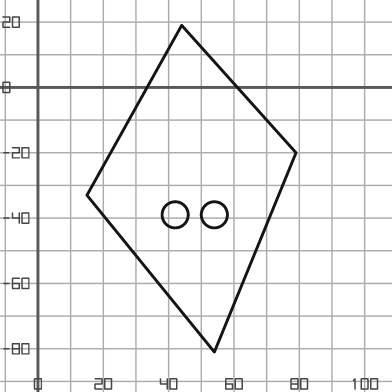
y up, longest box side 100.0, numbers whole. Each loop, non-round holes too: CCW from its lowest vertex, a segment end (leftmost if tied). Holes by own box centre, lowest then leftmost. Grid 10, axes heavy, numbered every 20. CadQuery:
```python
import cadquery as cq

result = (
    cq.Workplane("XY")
    .moveTo(54.0, -81.0)
    .lineTo(79.0, -20.0)
    .lineTo(44.0, 19.0)
    .lineTo(15.0, -33.0)
    .close()
    .moveTo(42.0, -39.0)
    .circle(4.0)
    .moveTo(54.0, -39.0)
    .circle(4.0)
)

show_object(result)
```